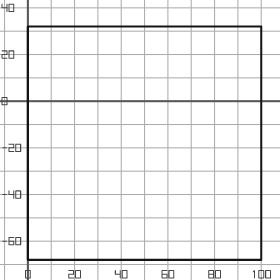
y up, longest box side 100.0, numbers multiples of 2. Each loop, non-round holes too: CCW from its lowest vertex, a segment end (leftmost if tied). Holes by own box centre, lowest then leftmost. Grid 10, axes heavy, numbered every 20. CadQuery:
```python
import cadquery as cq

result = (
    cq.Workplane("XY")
    .moveTo(0.0, -68.0)
    .lineTo(100.0, -68.0)
    .lineTo(100.0, 32.0)
    .lineTo(0.0, 32.0)
    .close()
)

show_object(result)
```